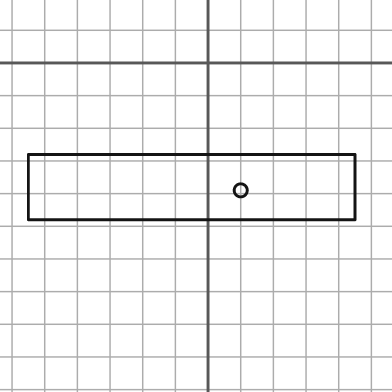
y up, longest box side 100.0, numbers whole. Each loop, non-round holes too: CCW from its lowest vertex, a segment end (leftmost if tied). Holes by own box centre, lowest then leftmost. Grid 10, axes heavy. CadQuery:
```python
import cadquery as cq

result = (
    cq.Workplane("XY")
    .moveTo(-55.0, -48.0)
    .lineTo(45.0, -48.0)
    .lineTo(45.0, -28.0)
    .lineTo(-55.0, -28.0)
    .close()
    .moveTo(10.0, -39.0)
    .circle(2.0)
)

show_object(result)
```